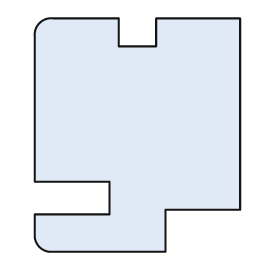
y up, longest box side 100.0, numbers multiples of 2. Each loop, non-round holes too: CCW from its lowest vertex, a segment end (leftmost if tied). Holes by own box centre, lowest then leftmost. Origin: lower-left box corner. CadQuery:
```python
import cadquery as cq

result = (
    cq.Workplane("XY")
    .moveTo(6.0, 0.0)
    .lineTo(56.0, 0.0)
    .lineTo(56.0, 18.0)
    .lineTo(88.0, 18.0)
    .lineTo(88.0, 100.0)
    .lineTo(52.0, 100.0)
    .lineTo(52.0, 88.0)
    .lineTo(36.0, 88.0)
    .lineTo(36.0, 100.0)
    .lineTo(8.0, 100.0)
    .threePointArc((2.0, 98.0), (0.0, 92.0))
    .lineTo(0.0, 30.0)
    .lineTo(32.0, 30.0)
    .lineTo(32.0, 16.0)
    .lineTo(0.0, 16.0)
    .lineTo(0.0, 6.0)
    .threePointArc((2.0, 2.0), (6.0, 0.0))
    .close()
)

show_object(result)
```